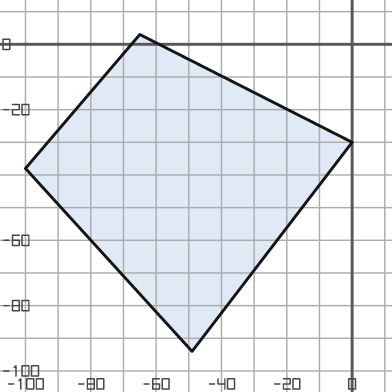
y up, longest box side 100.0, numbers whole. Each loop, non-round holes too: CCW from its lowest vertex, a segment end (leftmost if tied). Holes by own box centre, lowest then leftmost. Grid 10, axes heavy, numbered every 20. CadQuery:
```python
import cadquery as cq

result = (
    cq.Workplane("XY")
    .moveTo(-49.0, -94.0)
    .lineTo(0.0, -30.0)
    .lineTo(-65.0, 3.0)
    .lineTo(-100.0, -38.0)
    .close()
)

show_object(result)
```